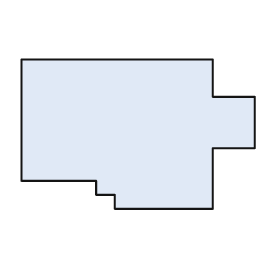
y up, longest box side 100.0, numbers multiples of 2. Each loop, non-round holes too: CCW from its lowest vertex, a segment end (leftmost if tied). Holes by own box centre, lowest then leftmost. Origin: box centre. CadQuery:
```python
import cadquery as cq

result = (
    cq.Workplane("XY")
    .moveTo(-10.0, -32.0)
    .lineTo(32.0, -32.0)
    .lineTo(32.0, -6.0)
    .lineTo(50.0, -6.0)
    .lineTo(50.0, 16.0)
    .lineTo(32.0, 16.0)
    .lineTo(32.0, 32.0)
    .lineTo(-50.0, 32.0)
    .lineTo(-50.0, -20.0)
    .lineTo(-18.0, -20.0)
    .lineTo(-18.0, -26.0)
    .lineTo(-10.0, -26.0)
    .close()
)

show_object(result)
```